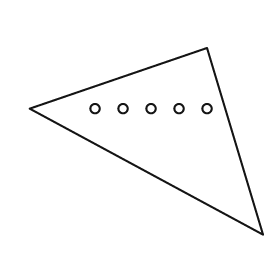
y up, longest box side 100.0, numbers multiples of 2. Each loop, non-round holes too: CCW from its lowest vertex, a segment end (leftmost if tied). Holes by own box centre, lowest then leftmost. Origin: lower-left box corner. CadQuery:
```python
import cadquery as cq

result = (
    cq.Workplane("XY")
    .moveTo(100.0, 0.0)
    .lineTo(76.0, 80.0)
    .lineTo(0.0, 54.0)
    .close()
    .moveTo(28.0, 54.0)
    .circle(2.0)
    .moveTo(40.0, 54.0)
    .circle(2.0)
    .moveTo(52.0, 54.0)
    .circle(2.0)
    .moveTo(64.0, 54.0)
    .circle(2.0)
    .moveTo(76.0, 54.0)
    .circle(2.0)
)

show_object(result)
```